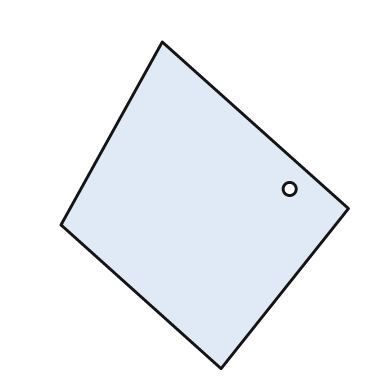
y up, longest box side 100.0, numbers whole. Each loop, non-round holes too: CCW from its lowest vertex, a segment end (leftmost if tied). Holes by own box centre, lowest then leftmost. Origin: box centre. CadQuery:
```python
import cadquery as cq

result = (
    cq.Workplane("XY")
    .moveTo(5.0, -50.0)
    .lineTo(44.0, -1.0)
    .lineTo(-13.0, 50.0)
    .lineTo(-44.0, -6.0)
    .close()
    .moveTo(26.0, 5.0)
    .circle(2.0)
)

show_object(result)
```